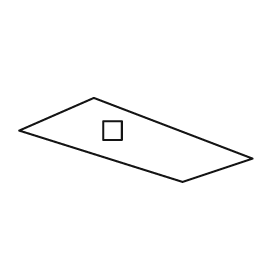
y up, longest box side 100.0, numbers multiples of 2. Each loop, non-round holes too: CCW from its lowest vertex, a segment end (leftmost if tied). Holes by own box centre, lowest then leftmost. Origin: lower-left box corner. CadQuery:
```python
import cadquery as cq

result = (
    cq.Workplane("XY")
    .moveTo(70.0, 0.0)
    .lineTo(100.0, 10.0)
    .lineTo(32.0, 36.0)
    .lineTo(0.0, 22.0)
    .close()
    .moveTo(36.0, 18.0)
    .lineTo(44.0, 18.0)
    .lineTo(44.0, 26.0)
    .lineTo(36.0, 26.0)
    .close()
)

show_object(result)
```